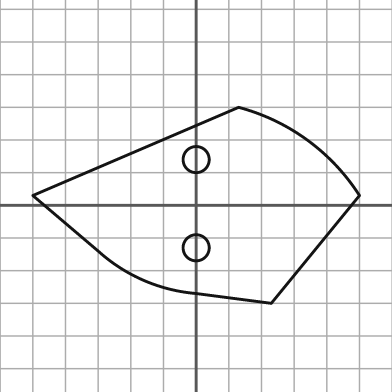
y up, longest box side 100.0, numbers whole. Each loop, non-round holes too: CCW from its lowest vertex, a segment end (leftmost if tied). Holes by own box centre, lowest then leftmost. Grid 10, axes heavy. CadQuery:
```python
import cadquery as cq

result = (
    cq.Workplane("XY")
    .moveTo(23.0, -30.0)
    .lineTo(50.0, 3.0)
    .threePointArc((34.0, 20.0), (13.0, 30.0))
    .lineTo(-50.0, 3.0)
    .lineTo(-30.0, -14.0)
    .threePointArc((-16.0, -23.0), (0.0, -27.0))
    .close()
    .moveTo(0.0, -13.0)
    .circle(4.0)
    .moveTo(0.0, 14.0)
    .circle(4.0)
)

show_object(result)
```